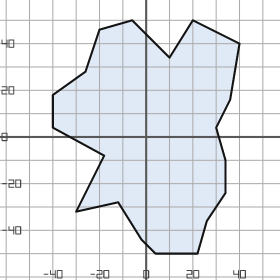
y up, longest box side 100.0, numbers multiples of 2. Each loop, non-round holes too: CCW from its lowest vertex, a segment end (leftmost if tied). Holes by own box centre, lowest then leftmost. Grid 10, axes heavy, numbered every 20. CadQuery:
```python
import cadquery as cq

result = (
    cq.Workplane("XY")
    .moveTo(4.0, -50.0)
    .lineTo(22.0, -50.0)
    .lineTo(26.0, -36.0)
    .lineTo(34.0, -24.0)
    .lineTo(34.0, -10.0)
    .lineTo(30.0, 4.0)
    .lineTo(36.0, 16.0)
    .lineTo(40.0, 40.0)
    .lineTo(20.0, 50.0)
    .lineTo(10.0, 34.0)
    .lineTo(-6.0, 50.0)
    .lineTo(-20.0, 46.0)
    .lineTo(-26.0, 28.0)
    .lineTo(-40.0, 18.0)
    .lineTo(-40.0, 4.0)
    .lineTo(-18.0, -8.0)
    .lineTo(-30.0, -32.0)
    .lineTo(-12.0, -28.0)
    .lineTo(-2.0, -44.0)
    .close()
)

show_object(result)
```